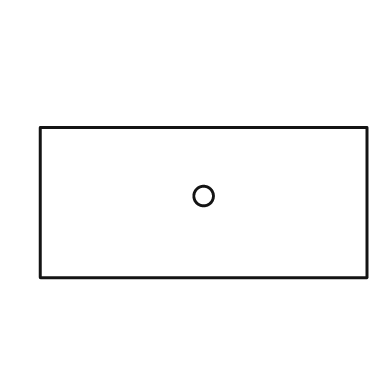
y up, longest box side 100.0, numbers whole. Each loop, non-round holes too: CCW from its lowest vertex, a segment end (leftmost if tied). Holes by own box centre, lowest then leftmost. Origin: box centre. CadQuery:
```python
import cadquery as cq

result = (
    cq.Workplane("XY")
    .moveTo(-50.0, -23.0)
    .lineTo(50.0, -23.0)
    .lineTo(50.0, 23.0)
    .lineTo(-50.0, 23.0)
    .close()
    .moveTo(0.0, 2.0)
    .circle(3.0)
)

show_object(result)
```